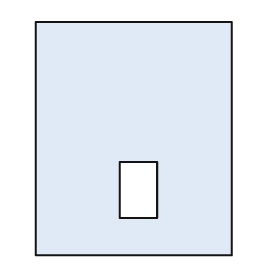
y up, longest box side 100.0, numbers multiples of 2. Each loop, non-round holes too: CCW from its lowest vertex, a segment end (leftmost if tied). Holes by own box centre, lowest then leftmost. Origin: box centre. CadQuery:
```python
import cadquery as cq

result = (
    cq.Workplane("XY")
    .moveTo(-42.0, -50.0)
    .lineTo(42.0, -50.0)
    .lineTo(42.0, 50.0)
    .lineTo(-42.0, 50.0)
    .close()
    .moveTo(-6.0, -34.0)
    .lineTo(10.0, -34.0)
    .lineTo(10.0, -10.0)
    .lineTo(-6.0, -10.0)
    .close()
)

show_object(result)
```